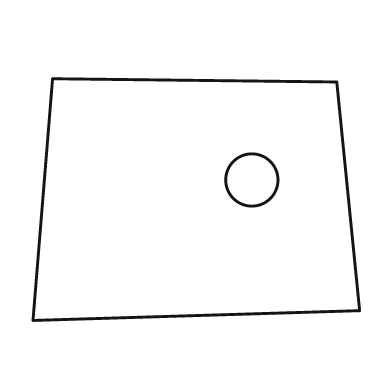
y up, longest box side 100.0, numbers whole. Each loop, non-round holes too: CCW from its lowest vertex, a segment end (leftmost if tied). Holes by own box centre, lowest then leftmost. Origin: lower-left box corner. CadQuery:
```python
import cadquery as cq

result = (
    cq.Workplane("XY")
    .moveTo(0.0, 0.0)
    .lineTo(100.0, 3.0)
    .lineTo(93.0, 73.0)
    .lineTo(6.0, 74.0)
    .close()
    .moveTo(67.0, 43.0)
    .circle(8.0)
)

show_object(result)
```